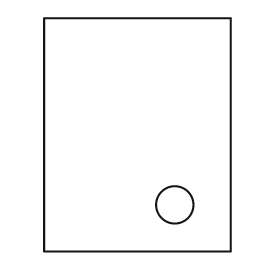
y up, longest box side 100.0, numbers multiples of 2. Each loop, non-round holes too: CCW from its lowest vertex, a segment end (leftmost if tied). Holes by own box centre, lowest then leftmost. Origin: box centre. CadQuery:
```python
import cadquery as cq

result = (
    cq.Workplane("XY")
    .moveTo(-40.0, -50.0)
    .lineTo(40.0, -50.0)
    .lineTo(40.0, 50.0)
    .lineTo(-40.0, 50.0)
    .close()
    .moveTo(16.0, -30.0)
    .circle(8.0)
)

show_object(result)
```